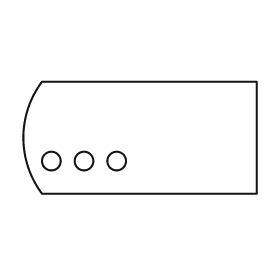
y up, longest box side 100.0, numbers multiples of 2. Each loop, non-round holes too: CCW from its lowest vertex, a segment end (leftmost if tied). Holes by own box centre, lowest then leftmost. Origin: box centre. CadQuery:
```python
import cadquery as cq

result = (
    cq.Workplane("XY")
    .moveTo(-42.0, -24.0)
    .lineTo(50.0, -24.0)
    .lineTo(50.0, 24.0)
    .lineTo(-42.0, 24.0)
    .threePointArc((-50.0, 0.0), (-42.0, -24.0))
    .close()
    .moveTo(-38.0, -10.0)
    .circle(4.0)
    .moveTo(-24.0, -10.0)
    .circle(4.0)
    .moveTo(-10.0, -10.0)
    .circle(4.0)
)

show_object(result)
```